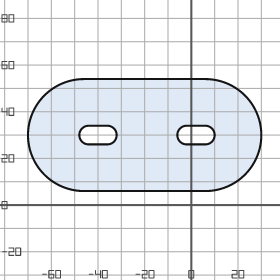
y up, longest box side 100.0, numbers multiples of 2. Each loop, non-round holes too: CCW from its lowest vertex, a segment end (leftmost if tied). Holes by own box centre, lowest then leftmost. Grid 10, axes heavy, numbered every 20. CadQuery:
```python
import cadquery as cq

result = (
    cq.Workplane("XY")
    .moveTo(-46.0, 6.0)
    .lineTo(6.0, 6.0)
    .threePointArc((30.0, 30.0), (6.0, 54.0))
    .lineTo(-46.0, 54.0)
    .threePointArc((-70.0, 30.0), (-46.0, 6.0))
    .close()
    .moveTo(-44.0, 26.0)
    .lineTo(-36.0, 26.0)
    .threePointArc((-32.0, 30.0), (-36.0, 34.0))
    .lineTo(-44.0, 34.0)
    .threePointArc((-48.0, 30.0), (-44.0, 26.0))
    .close()
    .moveTo(-2.0, 26.0)
    .lineTo(6.0, 26.0)
    .threePointArc((10.0, 30.0), (6.0, 34.0))
    .lineTo(-2.0, 34.0)
    .threePointArc((-6.0, 30.0), (-2.0, 26.0))
    .close()
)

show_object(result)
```